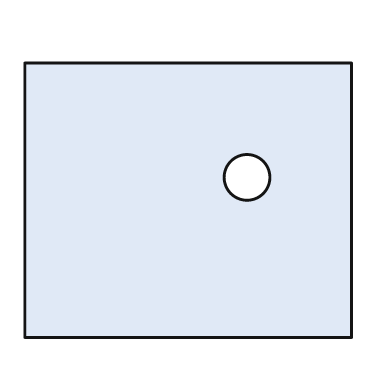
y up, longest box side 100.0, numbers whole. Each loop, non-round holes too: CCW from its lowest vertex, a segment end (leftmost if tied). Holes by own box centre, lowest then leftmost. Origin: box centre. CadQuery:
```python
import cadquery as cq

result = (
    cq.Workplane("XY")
    .moveTo(-50.0, -42.0)
    .lineTo(50.0, -42.0)
    .lineTo(50.0, 42.0)
    .lineTo(-50.0, 42.0)
    .close()
    .moveTo(18.0, 7.0)
    .circle(7.0)
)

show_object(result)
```